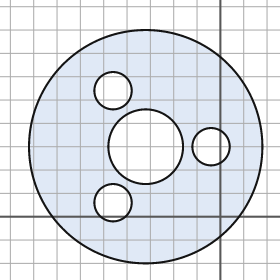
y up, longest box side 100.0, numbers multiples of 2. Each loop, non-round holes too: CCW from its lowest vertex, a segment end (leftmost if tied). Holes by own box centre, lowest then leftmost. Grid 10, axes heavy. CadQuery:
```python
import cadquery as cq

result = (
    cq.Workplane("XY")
    .moveTo(-32.0, 30.0)
    .circle(50.0)
    .moveTo(-46.0, 6.0)
    .circle(8.0)
    .moveTo(-32.0, 30.0)
    .circle(16.0)
    .moveTo(-4.0, 30.0)
    .circle(8.0)
    .moveTo(-46.0, 54.0)
    .circle(8.0)
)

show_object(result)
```